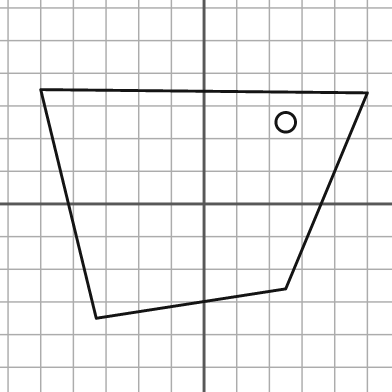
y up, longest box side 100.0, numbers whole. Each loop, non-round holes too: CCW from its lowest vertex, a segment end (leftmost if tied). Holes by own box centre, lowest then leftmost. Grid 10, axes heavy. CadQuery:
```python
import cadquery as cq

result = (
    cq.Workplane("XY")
    .moveTo(-33.0, -35.0)
    .lineTo(25.0, -26.0)
    .lineTo(50.0, 34.0)
    .lineTo(-50.0, 35.0)
    .close()
    .moveTo(25.0, 25.0)
    .circle(3.0)
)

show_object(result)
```